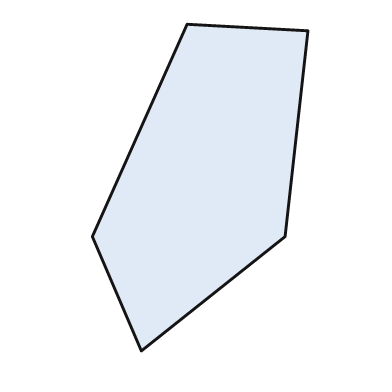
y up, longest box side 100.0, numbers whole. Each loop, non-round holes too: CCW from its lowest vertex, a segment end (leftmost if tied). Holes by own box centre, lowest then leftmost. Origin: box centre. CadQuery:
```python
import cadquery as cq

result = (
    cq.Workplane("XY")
    .moveTo(-18.0, -50.0)
    .lineTo(26.0, -15.0)
    .lineTo(33.0, 48.0)
    .lineTo(-4.0, 50.0)
    .lineTo(-33.0, -15.0)
    .close()
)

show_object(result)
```